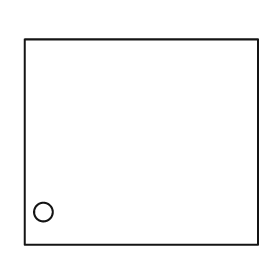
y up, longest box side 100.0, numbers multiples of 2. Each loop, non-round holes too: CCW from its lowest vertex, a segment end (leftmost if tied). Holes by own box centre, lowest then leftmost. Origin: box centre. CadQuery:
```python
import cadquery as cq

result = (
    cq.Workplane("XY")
    .moveTo(-50.0, -44.0)
    .lineTo(50.0, -44.0)
    .lineTo(50.0, 44.0)
    .lineTo(-50.0, 44.0)
    .close()
    .moveTo(-42.0, -30.0)
    .circle(4.0)
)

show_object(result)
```